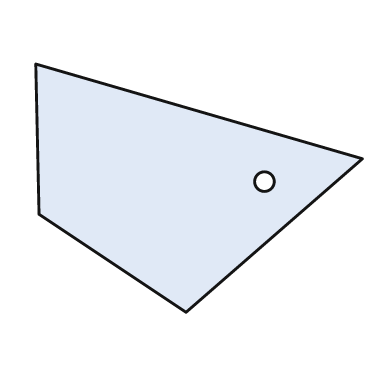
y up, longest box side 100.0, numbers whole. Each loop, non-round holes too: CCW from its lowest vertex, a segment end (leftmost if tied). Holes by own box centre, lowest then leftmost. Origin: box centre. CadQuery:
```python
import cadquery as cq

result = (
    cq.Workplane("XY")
    .moveTo(-4.0, -38.0)
    .lineTo(50.0, 9.0)
    .lineTo(-50.0, 38.0)
    .lineTo(-49.0, -8.0)
    .close()
    .moveTo(20.0, 2.0)
    .circle(3.0)
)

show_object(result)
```